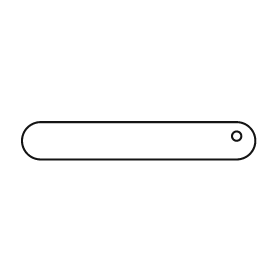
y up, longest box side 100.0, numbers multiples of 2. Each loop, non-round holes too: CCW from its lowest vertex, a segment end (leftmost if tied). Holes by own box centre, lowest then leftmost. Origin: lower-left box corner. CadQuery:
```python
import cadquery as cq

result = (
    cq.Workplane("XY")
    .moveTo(8.0, 0.0)
    .lineTo(92.0, 0.0)
    .threePointArc((100.0, 8.0), (92.0, 16.0))
    .lineTo(8.0, 16.0)
    .threePointArc((0.0, 8.0), (8.0, 0.0))
    .close()
    .moveTo(92.0, 10.0)
    .circle(2.0)
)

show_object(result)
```